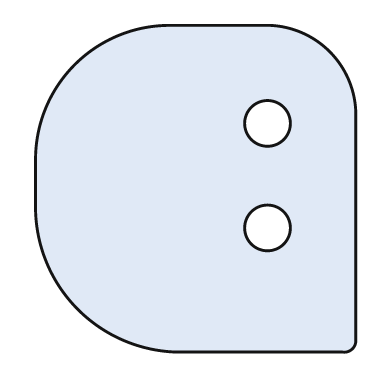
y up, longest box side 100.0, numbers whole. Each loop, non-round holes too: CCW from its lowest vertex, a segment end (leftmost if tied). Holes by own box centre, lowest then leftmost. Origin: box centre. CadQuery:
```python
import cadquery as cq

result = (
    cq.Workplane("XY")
    .moveTo(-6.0, -50.0)
    .lineTo(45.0, -50.0)
    .threePointArc((48.0, -49.0), (49.0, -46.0))
    .lineTo(49.0, 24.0)
    .threePointArc((41.0, 42.0), (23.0, 50.0))
    .lineTo(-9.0, 50.0)
    .threePointArc((-37.0, 38.0), (-49.0, 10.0))
    .lineTo(-49.0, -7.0)
    .threePointArc((-36.0, -37.0), (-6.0, -50.0))
    .close()
    .moveTo(22.0, -12.0)
    .circle(7.0)
    .moveTo(22.0, 20.0)
    .circle(7.0)
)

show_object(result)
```